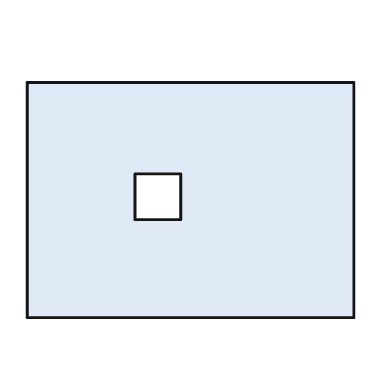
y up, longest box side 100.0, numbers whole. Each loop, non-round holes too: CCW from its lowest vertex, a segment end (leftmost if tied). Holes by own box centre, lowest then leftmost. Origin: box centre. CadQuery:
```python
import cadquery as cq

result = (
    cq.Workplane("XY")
    .moveTo(-50.0, -36.0)
    .lineTo(50.0, -36.0)
    .lineTo(50.0, 36.0)
    .lineTo(-50.0, 36.0)
    .close()
    .moveTo(-17.0, -6.0)
    .lineTo(-3.0, -6.0)
    .lineTo(-3.0, 8.0)
    .lineTo(-17.0, 8.0)
    .close()
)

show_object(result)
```